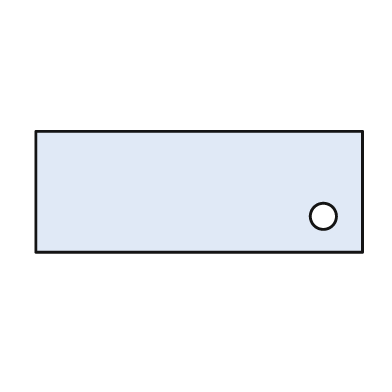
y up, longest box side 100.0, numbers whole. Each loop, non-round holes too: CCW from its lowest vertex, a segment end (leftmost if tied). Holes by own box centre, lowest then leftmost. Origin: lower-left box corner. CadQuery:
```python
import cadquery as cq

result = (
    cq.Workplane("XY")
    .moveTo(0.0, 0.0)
    .lineTo(100.0, 0.0)
    .lineTo(100.0, 37.0)
    .lineTo(0.0, 37.0)
    .close()
    .moveTo(88.0, 11.0)
    .circle(4.0)
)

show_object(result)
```